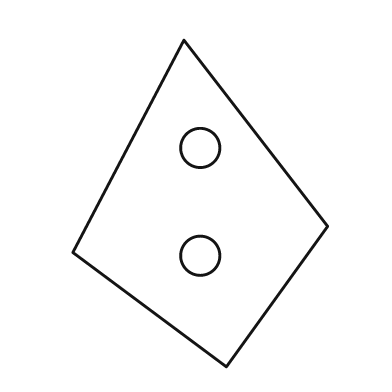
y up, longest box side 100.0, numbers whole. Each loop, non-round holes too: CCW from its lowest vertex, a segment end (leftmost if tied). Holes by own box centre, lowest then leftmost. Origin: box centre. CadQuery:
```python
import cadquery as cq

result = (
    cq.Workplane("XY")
    .moveTo(8.0, -50.0)
    .lineTo(39.0, -7.0)
    .lineTo(-5.0, 50.0)
    .lineTo(-39.0, -15.0)
    .close()
    .moveTo(0.0, -16.0)
    .circle(6.0)
    .moveTo(0.0, 17.0)
    .circle(6.0)
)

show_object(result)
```